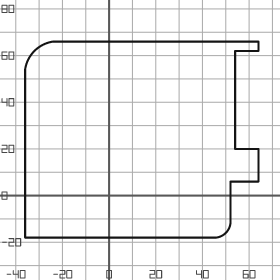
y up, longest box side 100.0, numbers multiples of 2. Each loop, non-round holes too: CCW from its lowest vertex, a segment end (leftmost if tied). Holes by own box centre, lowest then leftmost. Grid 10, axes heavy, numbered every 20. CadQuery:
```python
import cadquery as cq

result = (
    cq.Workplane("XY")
    .moveTo(-36.0, -18.0)
    .lineTo(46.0, -18.0)
    .threePointArc((50.0, -16.0), (52.0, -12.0))
    .lineTo(52.0, 6.0)
    .lineTo(64.0, 6.0)
    .lineTo(64.0, 20.0)
    .lineTo(54.0, 20.0)
    .lineTo(54.0, 62.0)
    .lineTo(64.0, 62.0)
    .lineTo(64.0, 66.0)
    .lineTo(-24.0, 66.0)
    .threePointArc((-32.0, 62.0), (-36.0, 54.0))
    .close()
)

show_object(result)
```